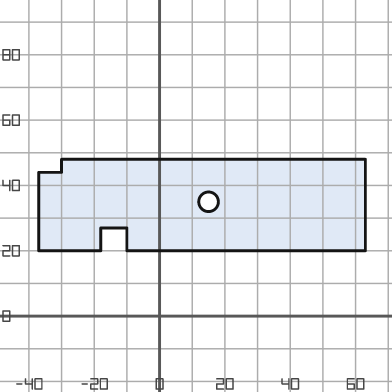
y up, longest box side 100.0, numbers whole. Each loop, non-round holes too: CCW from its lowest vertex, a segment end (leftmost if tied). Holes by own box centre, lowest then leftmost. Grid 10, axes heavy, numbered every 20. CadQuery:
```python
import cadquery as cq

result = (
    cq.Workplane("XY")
    .moveTo(-37.0, 20.0)
    .lineTo(-18.0, 20.0)
    .lineTo(-18.0, 27.0)
    .lineTo(-10.0, 27.0)
    .lineTo(-10.0, 20.0)
    .lineTo(63.0, 20.0)
    .lineTo(63.0, 48.0)
    .lineTo(-30.0, 48.0)
    .lineTo(-30.0, 44.0)
    .lineTo(-37.0, 44.0)
    .close()
    .moveTo(15.0, 35.0)
    .circle(3.0)
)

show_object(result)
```